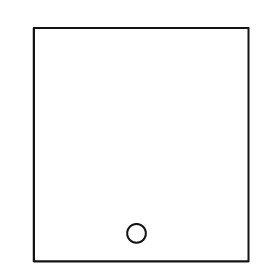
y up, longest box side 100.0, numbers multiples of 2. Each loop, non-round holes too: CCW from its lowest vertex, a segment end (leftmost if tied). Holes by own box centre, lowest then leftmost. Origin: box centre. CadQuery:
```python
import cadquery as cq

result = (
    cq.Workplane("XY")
    .moveTo(-46.0, -50.0)
    .lineTo(46.0, -50.0)
    .lineTo(46.0, 50.0)
    .lineTo(-46.0, 50.0)
    .close()
    .moveTo(-2.0, -38.0)
    .circle(4.0)
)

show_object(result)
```